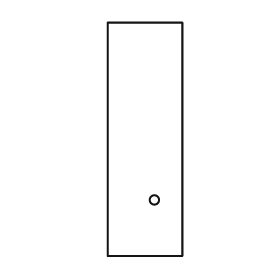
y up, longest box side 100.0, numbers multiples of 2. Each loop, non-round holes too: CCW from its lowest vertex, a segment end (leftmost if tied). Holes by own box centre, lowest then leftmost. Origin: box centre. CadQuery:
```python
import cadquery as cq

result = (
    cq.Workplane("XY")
    .moveTo(-16.0, -50.0)
    .lineTo(16.0, -50.0)
    .lineTo(16.0, 50.0)
    .lineTo(-16.0, 50.0)
    .close()
    .moveTo(4.0, -26.0)
    .circle(2.0)
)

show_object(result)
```